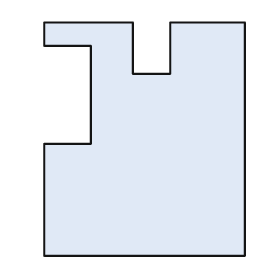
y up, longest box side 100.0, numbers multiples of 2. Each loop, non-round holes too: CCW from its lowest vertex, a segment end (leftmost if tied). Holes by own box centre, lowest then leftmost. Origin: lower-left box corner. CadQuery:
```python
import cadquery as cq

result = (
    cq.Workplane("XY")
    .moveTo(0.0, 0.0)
    .lineTo(86.0, 0.0)
    .lineTo(86.0, 100.0)
    .lineTo(54.0, 100.0)
    .lineTo(54.0, 78.0)
    .lineTo(38.0, 78.0)
    .lineTo(38.0, 100.0)
    .lineTo(0.0, 100.0)
    .lineTo(0.0, 90.0)
    .lineTo(20.0, 90.0)
    .lineTo(20.0, 48.0)
    .lineTo(0.0, 48.0)
    .close()
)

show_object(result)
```